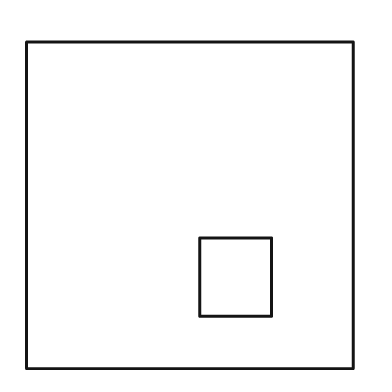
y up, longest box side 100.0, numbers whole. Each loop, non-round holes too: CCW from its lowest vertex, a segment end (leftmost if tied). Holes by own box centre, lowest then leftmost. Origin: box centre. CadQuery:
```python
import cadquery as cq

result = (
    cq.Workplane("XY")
    .moveTo(-50.0, -50.0)
    .lineTo(50.0, -50.0)
    .lineTo(50.0, 50.0)
    .lineTo(-50.0, 50.0)
    .close()
    .moveTo(3.0, -34.0)
    .lineTo(25.0, -34.0)
    .lineTo(25.0, -10.0)
    .lineTo(3.0, -10.0)
    .close()
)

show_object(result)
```